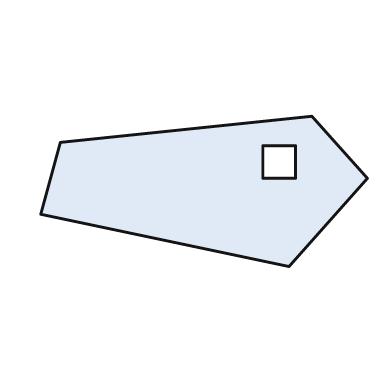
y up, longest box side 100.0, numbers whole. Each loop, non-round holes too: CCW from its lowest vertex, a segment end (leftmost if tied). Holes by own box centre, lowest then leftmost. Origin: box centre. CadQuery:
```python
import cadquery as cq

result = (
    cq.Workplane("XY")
    .moveTo(26.0, -23.0)
    .lineTo(50.0, 4.0)
    .lineTo(33.0, 23.0)
    .lineTo(-44.0, 15.0)
    .lineTo(-50.0, -7.0)
    .close()
    .moveTo(18.0, 4.0)
    .lineTo(28.0, 4.0)
    .lineTo(28.0, 14.0)
    .lineTo(18.0, 14.0)
    .close()
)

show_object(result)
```